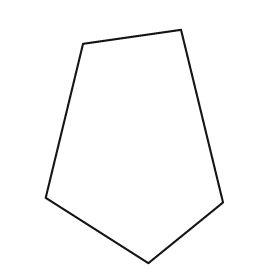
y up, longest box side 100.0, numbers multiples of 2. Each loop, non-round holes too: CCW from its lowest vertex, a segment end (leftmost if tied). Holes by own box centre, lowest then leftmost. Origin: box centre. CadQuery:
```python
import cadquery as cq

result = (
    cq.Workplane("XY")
    .moveTo(6.0, -50.0)
    .lineTo(38.0, -24.0)
    .lineTo(20.0, 50.0)
    .lineTo(-22.0, 44.0)
    .lineTo(-38.0, -22.0)
    .close()
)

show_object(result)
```